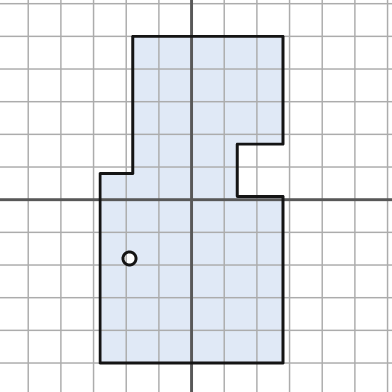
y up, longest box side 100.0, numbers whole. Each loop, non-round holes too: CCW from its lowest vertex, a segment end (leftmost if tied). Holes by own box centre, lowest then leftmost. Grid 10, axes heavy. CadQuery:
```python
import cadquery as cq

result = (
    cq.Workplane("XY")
    .moveTo(-28.0, -50.0)
    .lineTo(28.0, -50.0)
    .lineTo(28.0, 1.0)
    .lineTo(14.0, 1.0)
    .lineTo(14.0, 17.0)
    .lineTo(28.0, 17.0)
    .lineTo(28.0, 50.0)
    .lineTo(-18.0, 50.0)
    .lineTo(-18.0, 8.0)
    .lineTo(-28.0, 8.0)
    .close()
    .moveTo(-19.0, -18.0)
    .circle(2.0)
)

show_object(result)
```